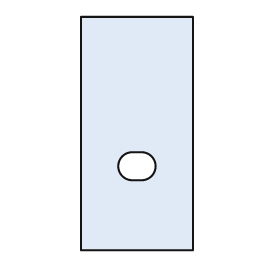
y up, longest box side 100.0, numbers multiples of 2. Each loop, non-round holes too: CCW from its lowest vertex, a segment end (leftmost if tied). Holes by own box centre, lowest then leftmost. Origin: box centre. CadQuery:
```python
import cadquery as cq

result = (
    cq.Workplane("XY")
    .moveTo(-24.0, -50.0)
    .lineTo(24.0, -50.0)
    .lineTo(24.0, 50.0)
    .lineTo(-24.0, 50.0)
    .close()
    .moveTo(-2.0, -20.0)
    .lineTo(2.0, -20.0)
    .threePointArc((8.0, -14.0), (2.0, -8.0))
    .lineTo(-2.0, -8.0)
    .threePointArc((-8.0, -14.0), (-2.0, -20.0))
    .close()
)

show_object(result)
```